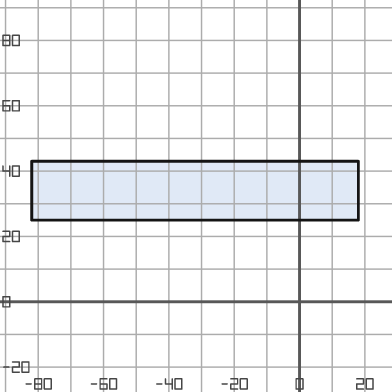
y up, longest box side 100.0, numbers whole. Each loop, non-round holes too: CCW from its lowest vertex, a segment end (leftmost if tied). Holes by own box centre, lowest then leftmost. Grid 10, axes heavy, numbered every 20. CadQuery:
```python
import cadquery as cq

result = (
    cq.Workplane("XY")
    .moveTo(-82.0, 25.0)
    .lineTo(18.0, 25.0)
    .lineTo(18.0, 43.0)
    .lineTo(-82.0, 43.0)
    .close()
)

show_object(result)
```